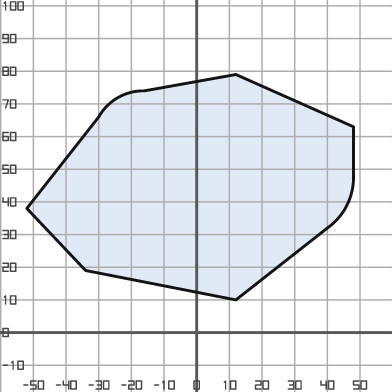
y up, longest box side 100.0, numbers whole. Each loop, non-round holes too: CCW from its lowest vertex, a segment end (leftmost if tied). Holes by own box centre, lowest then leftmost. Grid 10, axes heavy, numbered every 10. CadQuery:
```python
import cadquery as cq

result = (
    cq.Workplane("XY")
    .moveTo(12.0, 10.0)
    .lineTo(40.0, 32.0)
    .threePointArc((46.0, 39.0), (48.0, 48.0))
    .lineTo(48.0, 63.0)
    .lineTo(12.0, 79.0)
    .lineTo(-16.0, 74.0)
    .threePointArc((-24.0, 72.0), (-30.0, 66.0))
    .lineTo(-52.0, 38.0)
    .lineTo(-34.0, 19.0)
    .close()
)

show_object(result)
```